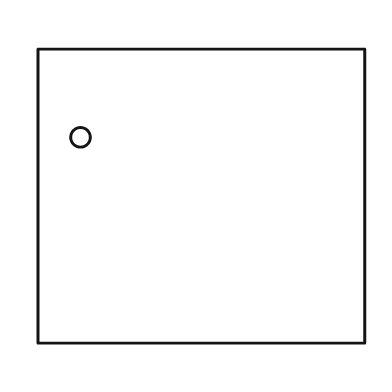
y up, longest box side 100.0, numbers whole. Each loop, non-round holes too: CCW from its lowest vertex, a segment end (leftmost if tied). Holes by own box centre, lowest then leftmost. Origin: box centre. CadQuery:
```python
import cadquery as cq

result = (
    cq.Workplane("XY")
    .moveTo(-50.0, -45.0)
    .lineTo(50.0, -45.0)
    .lineTo(50.0, 45.0)
    .lineTo(-50.0, 45.0)
    .close()
    .moveTo(-37.0, 18.0)
    .circle(3.0)
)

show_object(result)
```